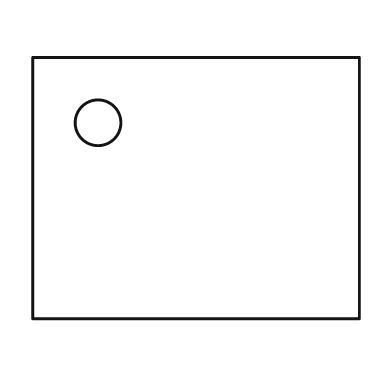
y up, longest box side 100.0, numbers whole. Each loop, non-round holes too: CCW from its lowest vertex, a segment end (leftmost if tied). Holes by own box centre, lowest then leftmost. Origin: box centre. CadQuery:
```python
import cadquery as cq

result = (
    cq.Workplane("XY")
    .moveTo(-50.0, -40.0)
    .lineTo(50.0, -40.0)
    .lineTo(50.0, 40.0)
    .lineTo(-50.0, 40.0)
    .close()
    .moveTo(-30.0, 20.0)
    .circle(7.0)
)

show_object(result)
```